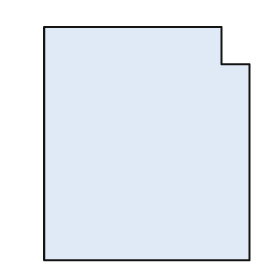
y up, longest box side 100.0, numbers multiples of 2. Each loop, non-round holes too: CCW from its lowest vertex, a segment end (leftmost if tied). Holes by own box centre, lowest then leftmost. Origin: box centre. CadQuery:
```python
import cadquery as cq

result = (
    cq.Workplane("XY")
    .moveTo(-44.0, -50.0)
    .lineTo(44.0, -50.0)
    .lineTo(44.0, 34.0)
    .lineTo(32.0, 34.0)
    .lineTo(32.0, 50.0)
    .lineTo(-44.0, 50.0)
    .close()
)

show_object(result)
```